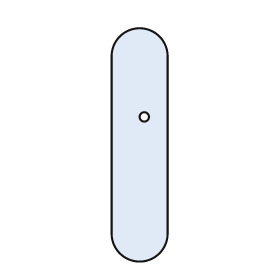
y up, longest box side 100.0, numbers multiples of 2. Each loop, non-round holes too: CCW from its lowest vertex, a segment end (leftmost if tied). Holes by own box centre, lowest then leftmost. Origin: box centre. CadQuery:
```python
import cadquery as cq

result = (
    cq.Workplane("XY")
    .moveTo(-12.0, -38.0)
    .threePointArc((0.0, -50.0), (12.0, -38.0))
    .lineTo(12.0, 38.0)
    .threePointArc((0.0, 50.0), (-12.0, 38.0))
    .close()
    .moveTo(2.0, 12.0)
    .circle(2.0)
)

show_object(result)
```